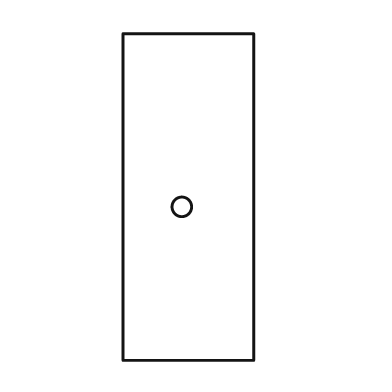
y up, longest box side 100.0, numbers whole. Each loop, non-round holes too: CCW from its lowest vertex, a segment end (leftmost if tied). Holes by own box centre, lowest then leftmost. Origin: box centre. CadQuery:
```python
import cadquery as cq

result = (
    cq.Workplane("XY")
    .moveTo(-20.0, -50.0)
    .lineTo(20.0, -50.0)
    .lineTo(20.0, 50.0)
    .lineTo(-20.0, 50.0)
    .close()
    .moveTo(-2.0, -3.0)
    .circle(3.0)
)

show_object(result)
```